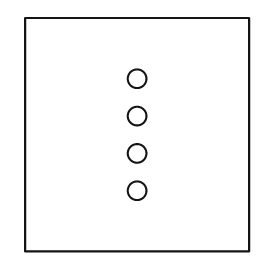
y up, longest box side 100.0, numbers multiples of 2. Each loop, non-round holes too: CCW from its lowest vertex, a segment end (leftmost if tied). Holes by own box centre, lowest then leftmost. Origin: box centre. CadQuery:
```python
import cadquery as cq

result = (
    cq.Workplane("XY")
    .moveTo(-48.0, -50.0)
    .lineTo(48.0, -50.0)
    .lineTo(48.0, 50.0)
    .lineTo(-48.0, 50.0)
    .close()
    .moveTo(0.0, -24.0)
    .circle(4.0)
    .moveTo(0.0, -8.0)
    .circle(4.0)
    .moveTo(0.0, 8.0)
    .circle(4.0)
    .moveTo(0.0, 24.0)
    .circle(4.0)
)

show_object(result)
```